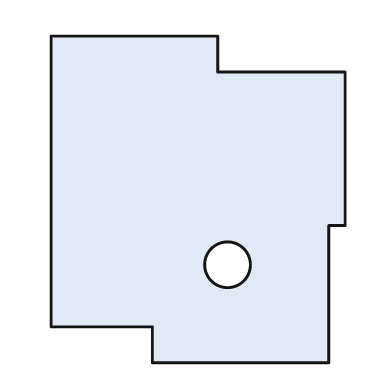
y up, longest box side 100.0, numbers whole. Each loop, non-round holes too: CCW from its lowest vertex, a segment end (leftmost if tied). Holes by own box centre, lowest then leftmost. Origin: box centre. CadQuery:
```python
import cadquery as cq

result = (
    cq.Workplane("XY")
    .moveTo(-14.0, -50.0)
    .lineTo(40.0, -50.0)
    .lineTo(40.0, -8.0)
    .lineTo(45.0, -8.0)
    .lineTo(45.0, 39.0)
    .lineTo(6.0, 39.0)
    .lineTo(6.0, 50.0)
    .lineTo(-45.0, 50.0)
    .lineTo(-45.0, -39.0)
    .lineTo(-14.0, -39.0)
    .close()
    .moveTo(9.0, -20.0)
    .circle(7.0)
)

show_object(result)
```